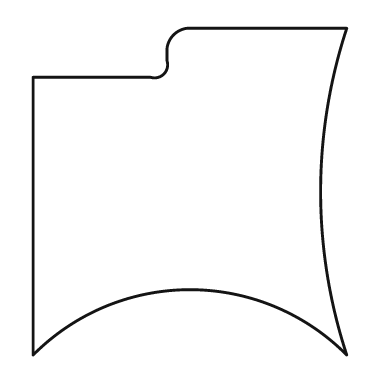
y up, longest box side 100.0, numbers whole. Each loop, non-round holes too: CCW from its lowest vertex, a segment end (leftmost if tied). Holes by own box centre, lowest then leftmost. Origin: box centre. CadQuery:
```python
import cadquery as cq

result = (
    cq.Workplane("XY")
    .moveTo(-48.0, -50.0)
    .threePointArc((0.0, -30.0), (48.0, -50.0))
    .threePointArc((40.0, 0.0), (48.0, 50.0))
    .lineTo(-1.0, 50.0)
    .threePointArc((-5.0, 48.0), (-7.0, 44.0))
    .lineTo(-7.0, 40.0)
    .threePointArc((-8.0, 36.0), (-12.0, 35.0))
    .lineTo(-48.0, 35.0)
    .close()
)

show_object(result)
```